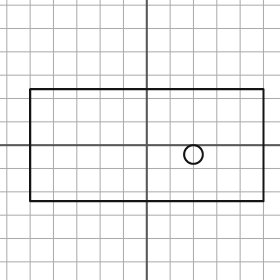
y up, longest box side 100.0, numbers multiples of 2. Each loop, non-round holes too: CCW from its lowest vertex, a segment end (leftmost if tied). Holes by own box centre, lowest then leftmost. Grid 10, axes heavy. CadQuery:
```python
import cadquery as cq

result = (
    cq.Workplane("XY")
    .moveTo(-50.0, -24.0)
    .lineTo(50.0, -24.0)
    .lineTo(50.0, 24.0)
    .lineTo(-50.0, 24.0)
    .close()
    .moveTo(20.0, -4.0)
    .circle(4.0)
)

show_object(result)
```